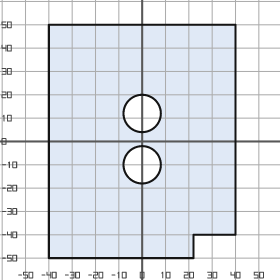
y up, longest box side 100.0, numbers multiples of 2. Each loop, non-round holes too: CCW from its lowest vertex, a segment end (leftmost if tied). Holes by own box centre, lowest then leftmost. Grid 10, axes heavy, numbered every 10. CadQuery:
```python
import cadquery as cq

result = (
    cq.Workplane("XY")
    .moveTo(-40.0, -50.0)
    .lineTo(22.0, -50.0)
    .lineTo(22.0, -40.0)
    .lineTo(40.0, -40.0)
    .lineTo(40.0, 50.0)
    .lineTo(-40.0, 50.0)
    .close()
    .moveTo(0.0, -10.0)
    .circle(8.0)
    .moveTo(0.0, 12.0)
    .circle(8.0)
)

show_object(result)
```